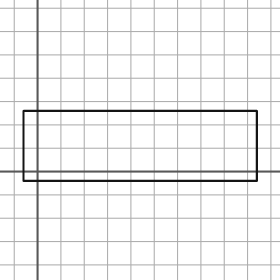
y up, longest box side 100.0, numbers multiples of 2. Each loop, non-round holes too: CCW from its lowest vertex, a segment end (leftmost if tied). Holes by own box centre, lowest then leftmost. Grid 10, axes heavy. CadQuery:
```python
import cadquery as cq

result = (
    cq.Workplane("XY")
    .moveTo(-6.0, -4.0)
    .lineTo(94.0, -4.0)
    .lineTo(94.0, 26.0)
    .lineTo(-6.0, 26.0)
    .close()
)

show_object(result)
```